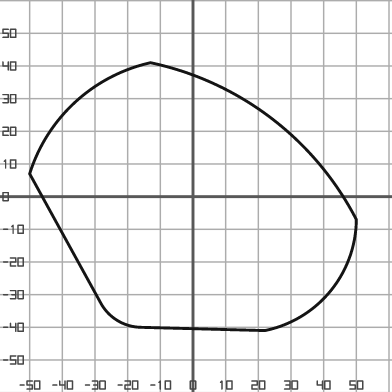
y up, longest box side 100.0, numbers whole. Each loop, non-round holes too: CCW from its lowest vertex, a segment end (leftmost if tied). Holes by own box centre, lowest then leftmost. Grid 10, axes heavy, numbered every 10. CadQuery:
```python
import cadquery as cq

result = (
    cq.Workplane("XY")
    .moveTo(22.0, -41.0)
    .threePointArc((42.0, -29.0), (50.0, -7.0))
    .threePointArc((24.0, 24.0), (-13.0, 41.0))
    .threePointArc((-36.0, 29.0), (-50.0, 7.0))
    .lineTo(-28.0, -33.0)
    .threePointArc((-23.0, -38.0), (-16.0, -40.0))
    .close()
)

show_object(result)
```